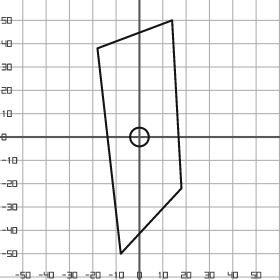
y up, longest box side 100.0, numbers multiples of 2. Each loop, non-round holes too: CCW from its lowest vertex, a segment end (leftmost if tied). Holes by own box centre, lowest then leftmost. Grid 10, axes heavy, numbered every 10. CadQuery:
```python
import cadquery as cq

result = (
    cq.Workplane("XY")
    .moveTo(-8.0, -50.0)
    .lineTo(18.0, -22.0)
    .lineTo(14.0, 50.0)
    .lineTo(-18.0, 38.0)
    .close()
    .moveTo(0.0, 0.0)
    .circle(4.0)
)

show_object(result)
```